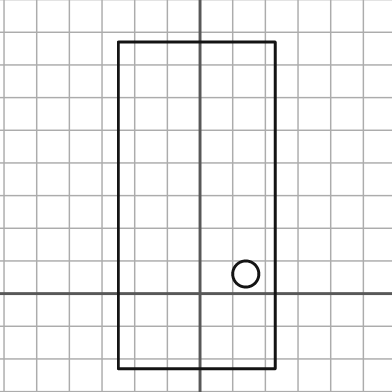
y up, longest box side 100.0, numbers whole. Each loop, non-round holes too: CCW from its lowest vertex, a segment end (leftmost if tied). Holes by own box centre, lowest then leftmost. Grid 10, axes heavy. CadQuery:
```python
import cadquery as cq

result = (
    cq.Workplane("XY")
    .moveTo(-25.0, -23.0)
    .lineTo(23.0, -23.0)
    .lineTo(23.0, 77.0)
    .lineTo(-25.0, 77.0)
    .close()
    .moveTo(14.0, 6.0)
    .circle(4.0)
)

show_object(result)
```